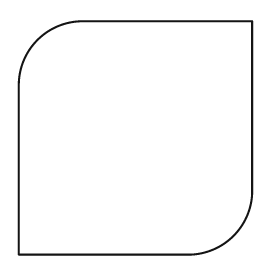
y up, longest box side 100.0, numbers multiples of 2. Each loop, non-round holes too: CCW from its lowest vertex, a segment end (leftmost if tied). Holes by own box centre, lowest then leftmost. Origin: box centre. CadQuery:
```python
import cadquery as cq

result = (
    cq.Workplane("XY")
    .moveTo(-50.0, -50.0)
    .lineTo(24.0, -50.0)
    .threePointArc((42.0, -42.0), (50.0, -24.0))
    .lineTo(50.0, 50.0)
    .lineTo(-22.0, 50.0)
    .threePointArc((-42.0, 42.0), (-50.0, 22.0))
    .close()
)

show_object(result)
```